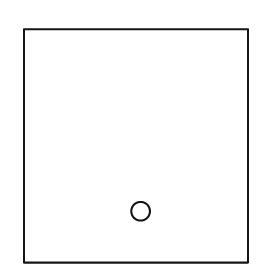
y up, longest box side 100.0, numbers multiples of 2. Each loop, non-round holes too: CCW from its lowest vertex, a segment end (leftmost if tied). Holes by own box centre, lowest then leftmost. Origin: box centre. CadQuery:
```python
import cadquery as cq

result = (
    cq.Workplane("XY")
    .moveTo(-48.0, -50.0)
    .lineTo(48.0, -50.0)
    .lineTo(48.0, 50.0)
    .lineTo(-48.0, 50.0)
    .close()
    .moveTo(2.0, -28.0)
    .circle(4.0)
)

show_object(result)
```